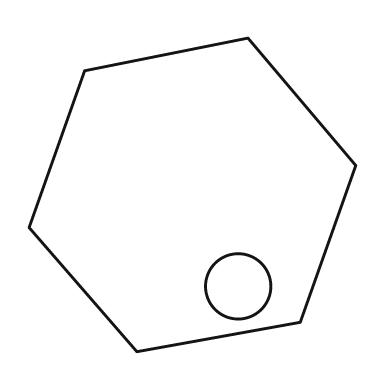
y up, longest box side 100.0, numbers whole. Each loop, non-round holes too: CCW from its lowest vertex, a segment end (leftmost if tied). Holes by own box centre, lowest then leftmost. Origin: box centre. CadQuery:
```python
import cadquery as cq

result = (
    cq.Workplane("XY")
    .moveTo(-17.0, -48.0)
    .lineTo(33.0, -39.0)
    .lineTo(50.0, 9.0)
    .lineTo(17.0, 48.0)
    .lineTo(-33.0, 38.0)
    .lineTo(-50.0, -10.0)
    .close()
    .moveTo(14.0, -28.0)
    .circle(10.0)
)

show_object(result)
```